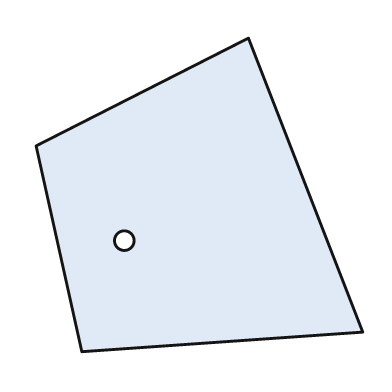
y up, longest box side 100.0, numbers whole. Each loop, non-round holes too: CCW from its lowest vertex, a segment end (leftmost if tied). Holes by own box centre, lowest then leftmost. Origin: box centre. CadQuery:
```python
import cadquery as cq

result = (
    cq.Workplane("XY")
    .moveTo(-36.0, -48.0)
    .lineTo(50.0, -42.0)
    .lineTo(15.0, 48.0)
    .lineTo(-50.0, 15.0)
    .close()
    .moveTo(-23.0, -14.0)
    .circle(3.0)
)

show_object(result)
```